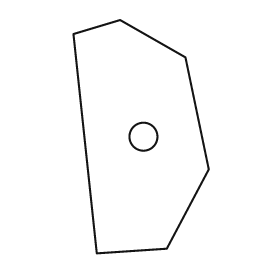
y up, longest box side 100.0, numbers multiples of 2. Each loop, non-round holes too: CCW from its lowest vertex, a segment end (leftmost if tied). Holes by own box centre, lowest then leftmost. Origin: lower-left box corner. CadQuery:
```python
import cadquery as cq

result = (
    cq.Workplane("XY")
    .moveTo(10.0, 0.0)
    .lineTo(40.0, 2.0)
    .lineTo(58.0, 36.0)
    .lineTo(48.0, 84.0)
    .lineTo(20.0, 100.0)
    .lineTo(0.0, 94.0)
    .close()
    .moveTo(30.0, 50.0)
    .circle(6.0)
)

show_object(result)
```